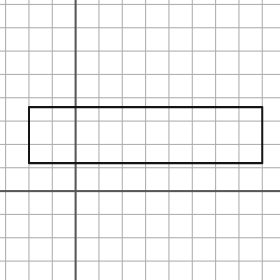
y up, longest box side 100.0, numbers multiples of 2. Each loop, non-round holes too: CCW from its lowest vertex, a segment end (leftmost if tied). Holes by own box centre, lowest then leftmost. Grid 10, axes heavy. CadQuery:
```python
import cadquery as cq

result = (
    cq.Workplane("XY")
    .moveTo(-20.0, 12.0)
    .lineTo(80.0, 12.0)
    .lineTo(80.0, 36.0)
    .lineTo(-20.0, 36.0)
    .close()
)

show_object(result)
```